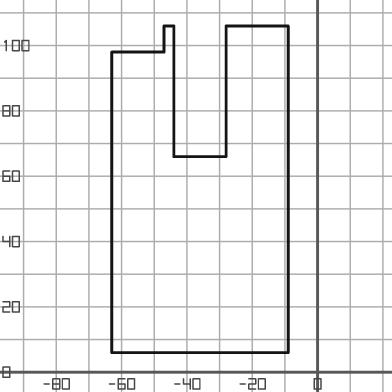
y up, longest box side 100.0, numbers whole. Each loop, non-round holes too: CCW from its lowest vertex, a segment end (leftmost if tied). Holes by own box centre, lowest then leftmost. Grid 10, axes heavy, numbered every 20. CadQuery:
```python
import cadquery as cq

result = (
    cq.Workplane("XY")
    .moveTo(-63.0, 6.0)
    .lineTo(-9.0, 6.0)
    .lineTo(-9.0, 106.0)
    .lineTo(-28.0, 106.0)
    .lineTo(-28.0, 66.0)
    .lineTo(-44.0, 66.0)
    .lineTo(-44.0, 106.0)
    .lineTo(-47.0, 106.0)
    .lineTo(-47.0, 98.0)
    .lineTo(-63.0, 98.0)
    .close()
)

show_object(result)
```